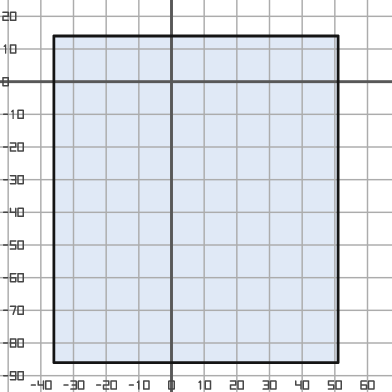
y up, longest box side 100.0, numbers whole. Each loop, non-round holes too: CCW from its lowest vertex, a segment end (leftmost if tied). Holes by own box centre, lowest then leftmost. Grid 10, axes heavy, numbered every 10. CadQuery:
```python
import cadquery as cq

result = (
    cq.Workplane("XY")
    .moveTo(-36.0, -86.0)
    .lineTo(51.0, -86.0)
    .lineTo(51.0, 14.0)
    .lineTo(-36.0, 14.0)
    .close()
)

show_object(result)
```